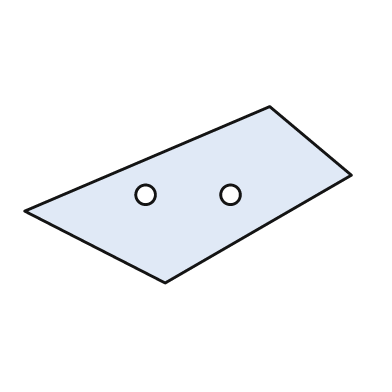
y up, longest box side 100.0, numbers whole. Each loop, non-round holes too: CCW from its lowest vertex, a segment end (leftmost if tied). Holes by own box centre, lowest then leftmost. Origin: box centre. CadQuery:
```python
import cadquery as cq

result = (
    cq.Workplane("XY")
    .moveTo(-7.0, -27.0)
    .lineTo(50.0, 6.0)
    .lineTo(25.0, 27.0)
    .lineTo(-50.0, -5.0)
    .close()
    .moveTo(-13.0, 0.0)
    .circle(3.0)
    .moveTo(13.0, 0.0)
    .circle(3.0)
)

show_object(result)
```